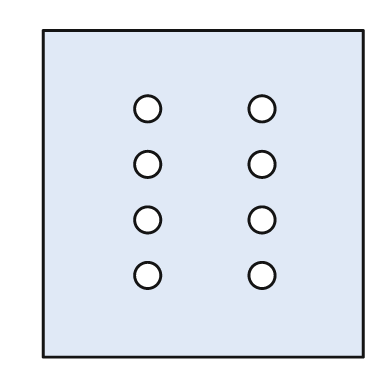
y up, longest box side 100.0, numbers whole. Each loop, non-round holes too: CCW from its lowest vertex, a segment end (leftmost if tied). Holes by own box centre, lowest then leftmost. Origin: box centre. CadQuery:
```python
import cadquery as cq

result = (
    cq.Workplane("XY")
    .moveTo(-49.0, -50.0)
    .lineTo(49.0, -50.0)
    .lineTo(49.0, 50.0)
    .lineTo(-49.0, 50.0)
    .close()
    .moveTo(-17.0, -25.0)
    .circle(4.0)
    .moveTo(18.0, -25.0)
    .circle(4.0)
    .moveTo(-17.0, -8.0)
    .circle(4.0)
    .moveTo(18.0, -8.0)
    .circle(4.0)
    .moveTo(-17.0, 9.0)
    .circle(4.0)
    .moveTo(18.0, 9.0)
    .circle(4.0)
    .moveTo(-17.0, 26.0)
    .circle(4.0)
    .moveTo(18.0, 26.0)
    .circle(4.0)
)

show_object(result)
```